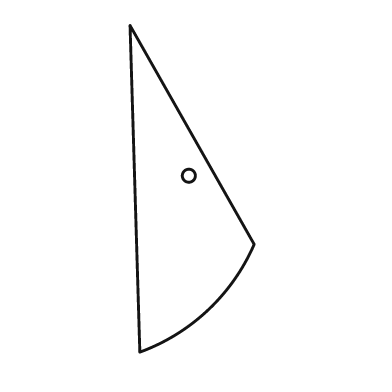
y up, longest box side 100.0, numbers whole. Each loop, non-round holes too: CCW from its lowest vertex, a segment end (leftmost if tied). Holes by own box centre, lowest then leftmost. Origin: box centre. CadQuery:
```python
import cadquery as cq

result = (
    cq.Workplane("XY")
    .moveTo(-16.0, -50.0)
    .threePointArc((5.0, -37.0), (19.0, -17.0))
    .lineTo(-19.0, 50.0)
    .close()
    .moveTo(-1.0, 4.0)
    .circle(2.0)
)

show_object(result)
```